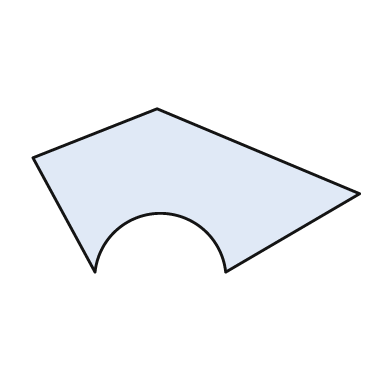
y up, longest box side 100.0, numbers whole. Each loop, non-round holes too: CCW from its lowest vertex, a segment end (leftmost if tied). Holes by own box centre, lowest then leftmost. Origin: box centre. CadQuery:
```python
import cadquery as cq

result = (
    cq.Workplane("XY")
    .moveTo(-31.0, -25.0)
    .threePointArc((-11.0, -7.0), (9.0, -25.0))
    .lineTo(50.0, -1.0)
    .lineTo(-12.0, 25.0)
    .lineTo(-50.0, 10.0)
    .close()
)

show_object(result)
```